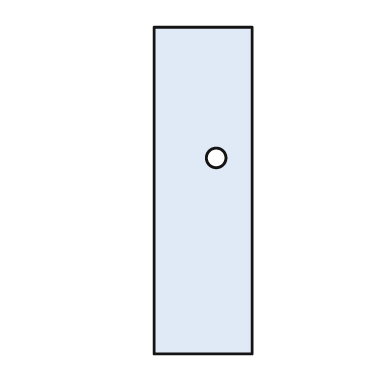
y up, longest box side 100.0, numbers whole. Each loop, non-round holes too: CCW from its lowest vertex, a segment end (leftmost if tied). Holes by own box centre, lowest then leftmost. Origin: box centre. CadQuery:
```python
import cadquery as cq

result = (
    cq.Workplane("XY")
    .moveTo(-15.0, -50.0)
    .lineTo(15.0, -50.0)
    .lineTo(15.0, 50.0)
    .lineTo(-15.0, 50.0)
    .close()
    .moveTo(4.0, 10.0)
    .circle(3.0)
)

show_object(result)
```